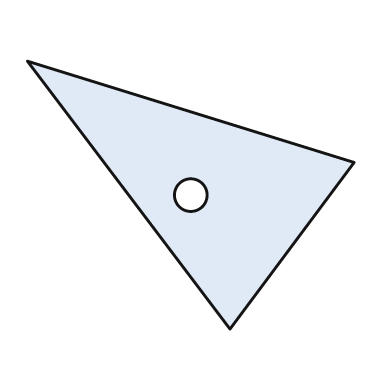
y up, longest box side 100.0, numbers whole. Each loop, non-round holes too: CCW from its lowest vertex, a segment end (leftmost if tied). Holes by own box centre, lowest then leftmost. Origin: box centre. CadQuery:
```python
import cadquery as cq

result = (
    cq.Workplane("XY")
    .moveTo(12.0, -41.0)
    .lineTo(50.0, 10.0)
    .lineTo(-50.0, 41.0)
    .close()
    .moveTo(0.0, 0.0)
    .circle(5.0)
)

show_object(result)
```